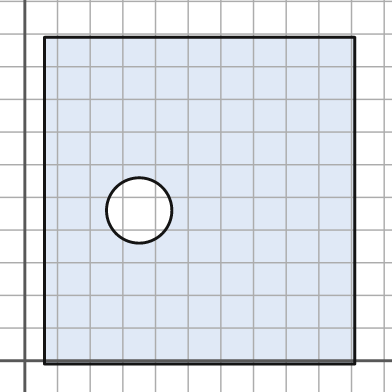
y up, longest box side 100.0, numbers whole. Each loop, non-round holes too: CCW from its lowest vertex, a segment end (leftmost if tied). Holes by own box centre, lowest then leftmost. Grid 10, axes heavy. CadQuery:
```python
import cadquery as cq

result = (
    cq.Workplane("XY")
    .moveTo(6.0, -1.0)
    .lineTo(101.0, -1.0)
    .lineTo(101.0, 99.0)
    .lineTo(6.0, 99.0)
    .close()
    .moveTo(35.0, 46.0)
    .circle(10.0)
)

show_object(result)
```